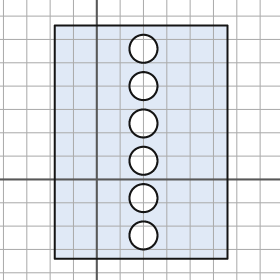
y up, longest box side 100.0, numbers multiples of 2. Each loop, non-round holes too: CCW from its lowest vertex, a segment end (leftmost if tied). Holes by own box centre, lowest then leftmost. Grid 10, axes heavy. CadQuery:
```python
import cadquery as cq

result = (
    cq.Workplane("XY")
    .moveTo(-18.0, -34.0)
    .lineTo(56.0, -34.0)
    .lineTo(56.0, 66.0)
    .lineTo(-18.0, 66.0)
    .close()
    .moveTo(20.0, -24.0)
    .circle(6.0)
    .moveTo(20.0, -8.0)
    .circle(6.0)
    .moveTo(20.0, 8.0)
    .circle(6.0)
    .moveTo(20.0, 24.0)
    .circle(6.0)
    .moveTo(20.0, 40.0)
    .circle(6.0)
    .moveTo(20.0, 56.0)
    .circle(6.0)
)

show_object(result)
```